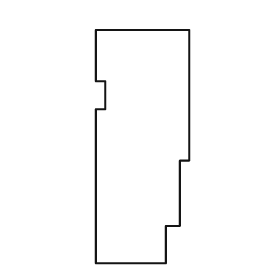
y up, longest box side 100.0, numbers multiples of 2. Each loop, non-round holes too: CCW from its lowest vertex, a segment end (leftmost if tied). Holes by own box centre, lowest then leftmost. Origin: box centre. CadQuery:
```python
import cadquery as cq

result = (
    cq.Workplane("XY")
    .moveTo(-20.0, -50.0)
    .lineTo(10.0, -50.0)
    .lineTo(10.0, -34.0)
    .lineTo(16.0, -34.0)
    .lineTo(16.0, -6.0)
    .lineTo(20.0, -6.0)
    .lineTo(20.0, 50.0)
    .lineTo(-20.0, 50.0)
    .lineTo(-20.0, 28.0)
    .lineTo(-16.0, 28.0)
    .lineTo(-16.0, 16.0)
    .lineTo(-20.0, 16.0)
    .close()
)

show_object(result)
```